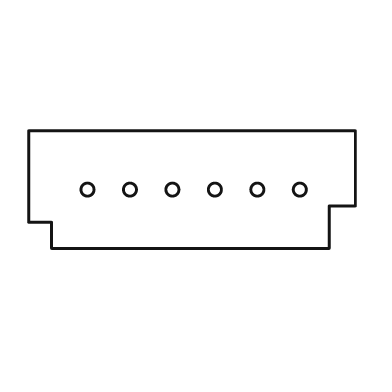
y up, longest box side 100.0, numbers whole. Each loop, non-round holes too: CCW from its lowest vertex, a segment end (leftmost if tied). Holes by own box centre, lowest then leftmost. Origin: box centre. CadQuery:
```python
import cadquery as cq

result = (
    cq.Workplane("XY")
    .moveTo(-43.0, -18.0)
    .lineTo(42.0, -18.0)
    .lineTo(42.0, -5.0)
    .lineTo(50.0, -5.0)
    .lineTo(50.0, 18.0)
    .lineTo(-50.0, 18.0)
    .lineTo(-50.0, -10.0)
    .lineTo(-43.0, -10.0)
    .close()
    .moveTo(-32.0, 0.0)
    .circle(2.0)
    .moveTo(-19.0, 0.0)
    .circle(2.0)
    .moveTo(-6.0, 0.0)
    .circle(2.0)
    .moveTo(7.0, 0.0)
    .circle(2.0)
    .moveTo(20.0, 0.0)
    .circle(2.0)
    .moveTo(33.0, 0.0)
    .circle(2.0)
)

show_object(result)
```